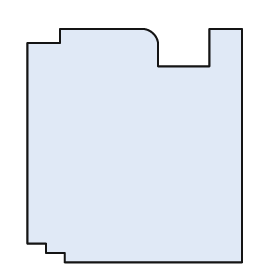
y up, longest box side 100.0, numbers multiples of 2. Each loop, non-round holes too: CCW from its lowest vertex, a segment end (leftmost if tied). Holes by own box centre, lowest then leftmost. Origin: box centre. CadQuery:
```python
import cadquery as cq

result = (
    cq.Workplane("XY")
    .moveTo(-30.0, -50.0)
    .lineTo(46.0, -50.0)
    .lineTo(46.0, 50.0)
    .lineTo(32.0, 50.0)
    .lineTo(32.0, 34.0)
    .lineTo(10.0, 34.0)
    .lineTo(10.0, 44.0)
    .threePointArc((8.0, 48.0), (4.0, 50.0))
    .lineTo(-32.0, 50.0)
    .lineTo(-32.0, 44.0)
    .lineTo(-46.0, 44.0)
    .lineTo(-46.0, -42.0)
    .lineTo(-38.0, -42.0)
    .lineTo(-38.0, -46.0)
    .lineTo(-30.0, -46.0)
    .close()
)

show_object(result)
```